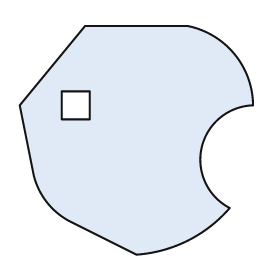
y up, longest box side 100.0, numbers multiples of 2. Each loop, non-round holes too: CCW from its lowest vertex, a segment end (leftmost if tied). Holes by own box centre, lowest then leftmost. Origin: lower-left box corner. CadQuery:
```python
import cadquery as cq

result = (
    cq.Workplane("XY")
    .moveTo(50.0, 0.0)
    .threePointArc((72.0, 6.0), (90.0, 20.0))
    .threePointArc((78.0, 46.0), (100.0, 64.0))
    .threePointArc((92.0, 86.0), (72.0, 98.0))
    .lineTo(28.0, 98.0)
    .lineTo(0.0, 64.0)
    .lineTo(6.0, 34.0)
    .threePointArc((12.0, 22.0), (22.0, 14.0))
    .close()
    .moveTo(18.0, 58.0)
    .lineTo(30.0, 58.0)
    .lineTo(30.0, 70.0)
    .lineTo(18.0, 70.0)
    .close()
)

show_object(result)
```